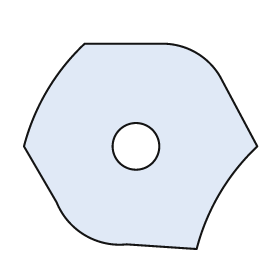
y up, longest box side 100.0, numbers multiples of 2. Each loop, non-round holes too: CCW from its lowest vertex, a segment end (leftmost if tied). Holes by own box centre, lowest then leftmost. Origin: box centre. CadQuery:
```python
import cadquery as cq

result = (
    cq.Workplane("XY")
    .moveTo(24.0, -44.0)
    .threePointArc((34.0, -20.0), (50.0, 0.0))
    .lineTo(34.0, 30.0)
    .threePointArc((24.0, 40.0), (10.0, 44.0))
    .lineTo(-24.0, 44.0)
    .threePointArc((-40.0, 24.0), (-50.0, 0.0))
    .lineTo(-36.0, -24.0)
    .threePointArc((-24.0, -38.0), (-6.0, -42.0))
    .close()
    .moveTo(-2.0, 0.0)
    .circle(10.0)
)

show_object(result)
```